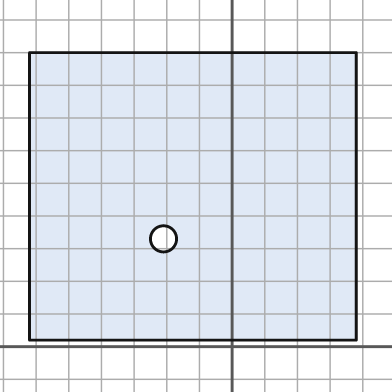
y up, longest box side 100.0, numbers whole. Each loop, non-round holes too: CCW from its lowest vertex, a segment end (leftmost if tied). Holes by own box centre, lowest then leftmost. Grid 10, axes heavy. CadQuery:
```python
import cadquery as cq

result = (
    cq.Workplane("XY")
    .moveTo(-62.0, 2.0)
    .lineTo(38.0, 2.0)
    .lineTo(38.0, 90.0)
    .lineTo(-62.0, 90.0)
    .close()
    .moveTo(-21.0, 33.0)
    .circle(4.0)
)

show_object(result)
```